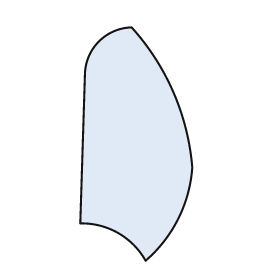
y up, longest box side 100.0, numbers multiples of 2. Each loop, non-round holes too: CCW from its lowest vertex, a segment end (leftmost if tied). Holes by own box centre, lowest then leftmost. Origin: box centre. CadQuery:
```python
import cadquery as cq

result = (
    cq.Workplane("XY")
    .moveTo(4.0, -50.0)
    .threePointArc((18.0, -32.0), (24.0, -10.0))
    .threePointArc((16.0, 22.0), (-2.0, 50.0))
    .threePointArc((-16.0, 44.0), (-22.0, 30.0))
    .lineTo(-24.0, -34.0)
    .threePointArc((-8.0, -38.0), (4.0, -50.0))
    .close()
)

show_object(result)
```